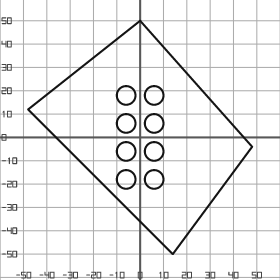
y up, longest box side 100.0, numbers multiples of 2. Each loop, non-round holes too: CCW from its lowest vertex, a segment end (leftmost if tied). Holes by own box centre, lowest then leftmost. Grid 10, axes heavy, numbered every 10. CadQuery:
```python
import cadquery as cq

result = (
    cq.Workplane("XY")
    .moveTo(14.0, -50.0)
    .lineTo(48.0, -4.0)
    .lineTo(0.0, 50.0)
    .lineTo(-48.0, 12.0)
    .close()
    .moveTo(-6.0, -18.0)
    .circle(4.0)
    .moveTo(6.0, -18.0)
    .circle(4.0)
    .moveTo(-6.0, -6.0)
    .circle(4.0)
    .moveTo(6.0, -6.0)
    .circle(4.0)
    .moveTo(-6.0, 6.0)
    .circle(4.0)
    .moveTo(6.0, 6.0)
    .circle(4.0)
    .moveTo(-6.0, 18.0)
    .circle(4.0)
    .moveTo(6.0, 18.0)
    .circle(4.0)
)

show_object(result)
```